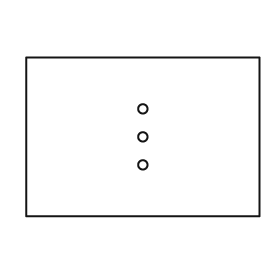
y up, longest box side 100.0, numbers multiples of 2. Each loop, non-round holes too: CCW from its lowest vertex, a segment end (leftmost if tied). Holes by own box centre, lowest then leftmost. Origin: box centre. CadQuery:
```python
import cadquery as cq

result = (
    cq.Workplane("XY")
    .moveTo(-50.0, -34.0)
    .lineTo(50.0, -34.0)
    .lineTo(50.0, 34.0)
    .lineTo(-50.0, 34.0)
    .close()
    .moveTo(0.0, -12.0)
    .circle(2.0)
    .moveTo(0.0, 0.0)
    .circle(2.0)
    .moveTo(0.0, 12.0)
    .circle(2.0)
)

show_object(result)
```